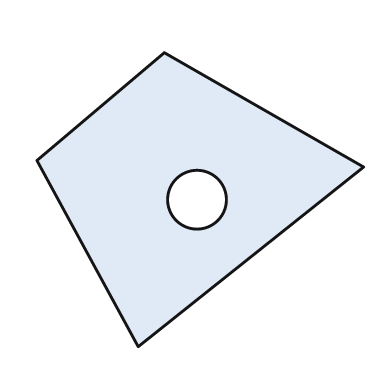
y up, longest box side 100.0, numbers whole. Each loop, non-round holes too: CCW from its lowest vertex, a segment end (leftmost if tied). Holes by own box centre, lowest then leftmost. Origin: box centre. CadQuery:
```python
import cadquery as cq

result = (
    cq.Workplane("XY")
    .moveTo(-19.0, -45.0)
    .lineTo(50.0, 10.0)
    .lineTo(-11.0, 45.0)
    .lineTo(-50.0, 12.0)
    .close()
    .moveTo(-1.0, 0.0)
    .circle(9.0)
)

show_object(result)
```